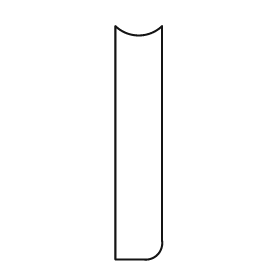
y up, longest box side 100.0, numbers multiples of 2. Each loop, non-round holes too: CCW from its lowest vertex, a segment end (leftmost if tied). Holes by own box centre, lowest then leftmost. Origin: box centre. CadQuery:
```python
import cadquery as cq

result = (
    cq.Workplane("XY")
    .moveTo(-10.0, -50.0)
    .lineTo(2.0, -50.0)
    .threePointArc((8.0, -48.0), (10.0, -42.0))
    .lineTo(10.0, 50.0)
    .threePointArc((0.0, 46.0), (-10.0, 50.0))
    .close()
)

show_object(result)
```